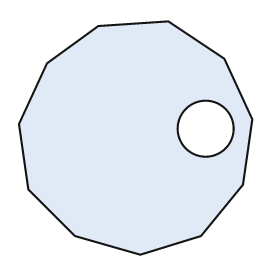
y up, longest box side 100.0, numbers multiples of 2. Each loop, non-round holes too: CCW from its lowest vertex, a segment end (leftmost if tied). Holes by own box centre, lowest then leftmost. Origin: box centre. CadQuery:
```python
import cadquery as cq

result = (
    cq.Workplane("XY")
    .moveTo(2.0, -50.0)
    .lineTo(28.0, -42.0)
    .lineTo(46.0, -20.0)
    .lineTo(50.0, 8.0)
    .lineTo(38.0, 34.0)
    .lineTo(14.0, 50.0)
    .lineTo(-16.0, 48.0)
    .lineTo(-38.0, 32.0)
    .lineTo(-50.0, 6.0)
    .lineTo(-46.0, -22.0)
    .lineTo(-26.0, -42.0)
    .close()
    .moveTo(30.0, 4.0)
    .circle(12.0)
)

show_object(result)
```